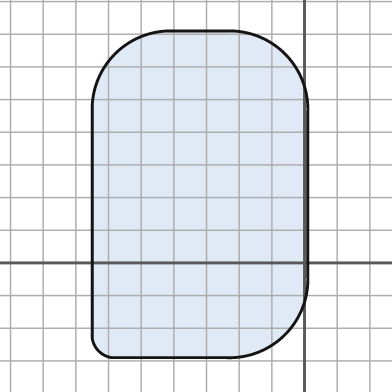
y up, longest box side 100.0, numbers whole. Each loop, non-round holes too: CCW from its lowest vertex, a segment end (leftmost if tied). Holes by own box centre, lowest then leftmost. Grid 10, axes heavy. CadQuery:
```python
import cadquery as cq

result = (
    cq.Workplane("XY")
    .moveTo(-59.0, -29.0)
    .lineTo(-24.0, -29.0)
    .threePointArc((-6.0, -22.0), (1.0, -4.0))
    .lineTo(1.0, 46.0)
    .threePointArc((-6.0, 64.0), (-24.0, 71.0))
    .lineTo(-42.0, 71.0)
    .threePointArc((-58.0, 64.0), (-65.0, 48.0))
    .lineTo(-65.0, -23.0)
    .threePointArc((-63.0, -27.0), (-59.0, -29.0))
    .close()
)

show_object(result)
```